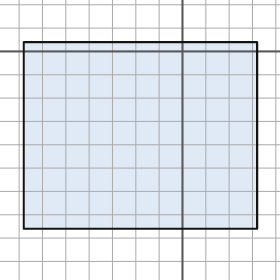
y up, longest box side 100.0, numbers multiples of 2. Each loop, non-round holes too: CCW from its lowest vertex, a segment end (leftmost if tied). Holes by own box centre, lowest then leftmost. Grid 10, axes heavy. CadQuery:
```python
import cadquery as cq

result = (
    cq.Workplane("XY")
    .moveTo(-68.0, -76.0)
    .lineTo(32.0, -76.0)
    .lineTo(32.0, 4.0)
    .lineTo(-68.0, 4.0)
    .close()
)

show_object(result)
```